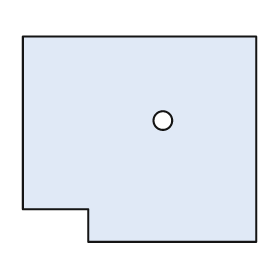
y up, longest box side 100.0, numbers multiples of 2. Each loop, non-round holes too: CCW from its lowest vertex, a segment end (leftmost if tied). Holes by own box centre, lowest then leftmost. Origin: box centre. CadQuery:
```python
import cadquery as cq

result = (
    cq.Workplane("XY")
    .moveTo(-22.0, -44.0)
    .lineTo(50.0, -44.0)
    .lineTo(50.0, 44.0)
    .lineTo(-50.0, 44.0)
    .lineTo(-50.0, -30.0)
    .lineTo(-22.0, -30.0)
    .close()
    .moveTo(10.0, 8.0)
    .circle(4.0)
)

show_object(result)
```